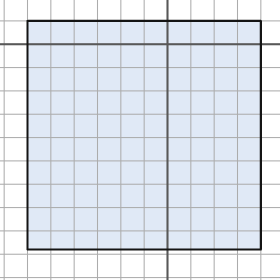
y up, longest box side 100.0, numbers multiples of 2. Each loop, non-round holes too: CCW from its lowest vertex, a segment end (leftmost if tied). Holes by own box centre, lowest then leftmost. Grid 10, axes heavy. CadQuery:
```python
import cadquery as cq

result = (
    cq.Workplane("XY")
    .moveTo(-60.0, -88.0)
    .lineTo(40.0, -88.0)
    .lineTo(40.0, 10.0)
    .lineTo(-60.0, 10.0)
    .close()
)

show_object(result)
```